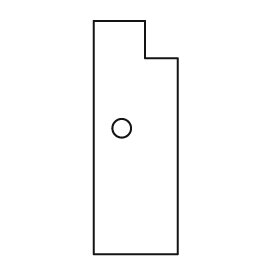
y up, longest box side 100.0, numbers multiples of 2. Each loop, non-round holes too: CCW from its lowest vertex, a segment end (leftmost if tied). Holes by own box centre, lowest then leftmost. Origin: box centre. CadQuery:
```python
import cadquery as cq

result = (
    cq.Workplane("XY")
    .moveTo(-18.0, -50.0)
    .lineTo(18.0, -50.0)
    .lineTo(18.0, 34.0)
    .lineTo(4.0, 34.0)
    .lineTo(4.0, 50.0)
    .lineTo(-18.0, 50.0)
    .close()
    .moveTo(-6.0, 4.0)
    .circle(4.0)
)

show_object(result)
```